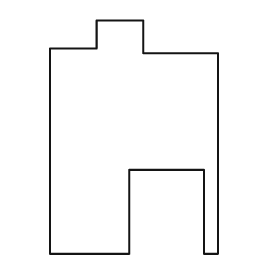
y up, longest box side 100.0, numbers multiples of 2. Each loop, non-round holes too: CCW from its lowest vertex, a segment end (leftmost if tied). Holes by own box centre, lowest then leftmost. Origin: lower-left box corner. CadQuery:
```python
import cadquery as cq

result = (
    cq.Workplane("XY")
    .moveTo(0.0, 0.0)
    .lineTo(34.0, 0.0)
    .lineTo(34.0, 36.0)
    .lineTo(66.0, 36.0)
    .lineTo(66.0, 0.0)
    .lineTo(72.0, 0.0)
    .lineTo(72.0, 86.0)
    .lineTo(40.0, 86.0)
    .lineTo(40.0, 100.0)
    .lineTo(20.0, 100.0)
    .lineTo(20.0, 88.0)
    .lineTo(0.0, 88.0)
    .close()
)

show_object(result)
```